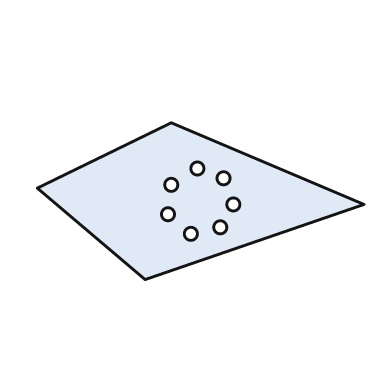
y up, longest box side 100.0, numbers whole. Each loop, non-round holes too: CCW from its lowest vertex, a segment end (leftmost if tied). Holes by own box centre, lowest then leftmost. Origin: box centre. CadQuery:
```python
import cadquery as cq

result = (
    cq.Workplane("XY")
    .moveTo(-17.0, -24.0)
    .lineTo(50.0, -1.0)
    .lineTo(-9.0, 24.0)
    .lineTo(-50.0, 4.0)
    .close()
    .moveTo(-3.0, -10.0)
    .circle(2.0)
    .moveTo(6.0, -8.0)
    .circle(2.0)
    .moveTo(-10.0, -4.0)
    .circle(2.0)
    .moveTo(10.0, -1.0)
    .circle(2.0)
    .moveTo(-9.0, 5.0)
    .circle(2.0)
    .moveTo(7.0, 7.0)
    .circle(2.0)
    .moveTo(-1.0, 10.0)
    .circle(2.0)
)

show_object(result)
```